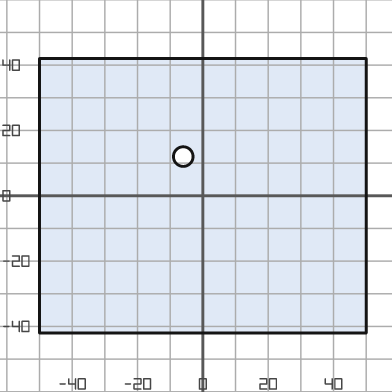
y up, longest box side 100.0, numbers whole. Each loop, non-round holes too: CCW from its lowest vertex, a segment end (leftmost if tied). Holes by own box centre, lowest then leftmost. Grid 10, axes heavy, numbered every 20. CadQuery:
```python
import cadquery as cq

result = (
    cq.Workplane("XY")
    .moveTo(-50.0, -42.0)
    .lineTo(50.0, -42.0)
    .lineTo(50.0, 42.0)
    .lineTo(-50.0, 42.0)
    .close()
    .moveTo(-6.0, 12.0)
    .circle(3.0)
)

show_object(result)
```